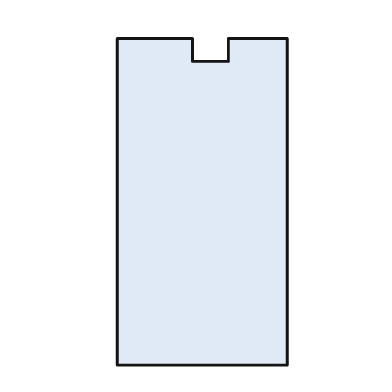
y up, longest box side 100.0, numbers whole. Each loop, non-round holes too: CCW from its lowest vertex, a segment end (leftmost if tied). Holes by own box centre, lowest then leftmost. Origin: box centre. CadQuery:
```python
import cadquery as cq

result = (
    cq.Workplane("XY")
    .moveTo(-26.0, -50.0)
    .lineTo(26.0, -50.0)
    .lineTo(26.0, 50.0)
    .lineTo(8.0, 50.0)
    .lineTo(8.0, 43.0)
    .lineTo(-3.0, 43.0)
    .lineTo(-3.0, 50.0)
    .lineTo(-26.0, 50.0)
    .close()
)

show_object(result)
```